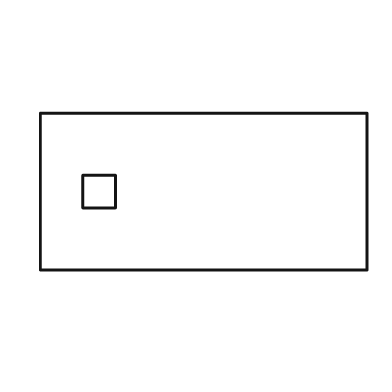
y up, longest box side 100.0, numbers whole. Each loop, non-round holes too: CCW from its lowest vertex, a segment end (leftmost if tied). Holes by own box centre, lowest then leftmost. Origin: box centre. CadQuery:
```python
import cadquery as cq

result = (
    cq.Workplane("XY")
    .moveTo(-50.0, -24.0)
    .lineTo(50.0, -24.0)
    .lineTo(50.0, 24.0)
    .lineTo(-50.0, 24.0)
    .close()
    .moveTo(-37.0, -5.0)
    .lineTo(-27.0, -5.0)
    .lineTo(-27.0, 5.0)
    .lineTo(-37.0, 5.0)
    .close()
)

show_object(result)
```